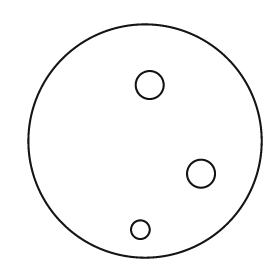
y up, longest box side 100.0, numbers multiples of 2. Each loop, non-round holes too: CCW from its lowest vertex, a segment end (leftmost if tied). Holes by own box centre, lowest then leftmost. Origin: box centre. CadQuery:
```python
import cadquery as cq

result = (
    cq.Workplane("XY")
    .moveTo(0.0, 0.0)
    .circle(50.0)
    .moveTo(-2.0, -38.0)
    .circle(4.0)
    .moveTo(24.0, -14.0)
    .circle(6.0)
    .moveTo(2.0, 24.0)
    .circle(6.0)
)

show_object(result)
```